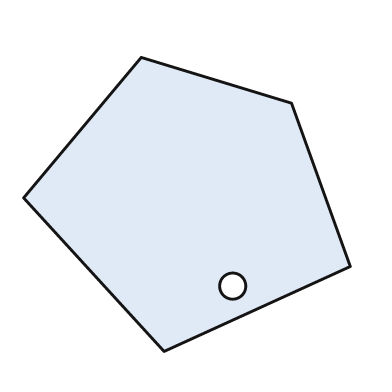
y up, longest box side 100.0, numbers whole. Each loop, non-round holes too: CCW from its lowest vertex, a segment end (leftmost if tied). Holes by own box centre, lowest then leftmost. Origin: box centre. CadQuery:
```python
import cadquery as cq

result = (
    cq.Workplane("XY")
    .moveTo(-7.0, -45.0)
    .lineTo(50.0, -19.0)
    .lineTo(32.0, 31.0)
    .lineTo(-14.0, 45.0)
    .lineTo(-50.0, 2.0)
    .close()
    .moveTo(14.0, -25.0)
    .circle(4.0)
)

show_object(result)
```